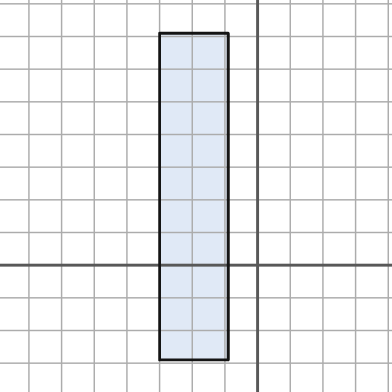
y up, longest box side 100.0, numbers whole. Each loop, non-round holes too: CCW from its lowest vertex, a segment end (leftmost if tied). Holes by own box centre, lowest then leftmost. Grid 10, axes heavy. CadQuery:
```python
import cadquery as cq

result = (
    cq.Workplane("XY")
    .moveTo(-30.0, -29.0)
    .lineTo(-9.0, -29.0)
    .lineTo(-9.0, 71.0)
    .lineTo(-30.0, 71.0)
    .close()
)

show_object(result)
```